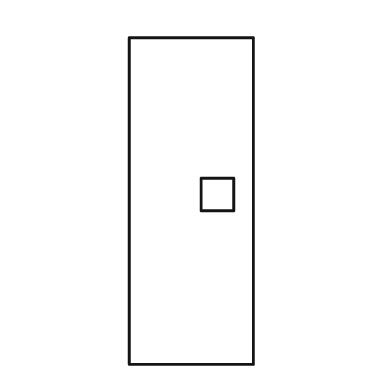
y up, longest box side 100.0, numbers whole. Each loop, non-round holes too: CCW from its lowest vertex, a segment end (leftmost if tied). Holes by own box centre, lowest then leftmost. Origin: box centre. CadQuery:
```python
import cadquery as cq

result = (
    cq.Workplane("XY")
    .moveTo(-19.0, -50.0)
    .lineTo(19.0, -50.0)
    .lineTo(19.0, 50.0)
    .lineTo(-19.0, 50.0)
    .close()
    .moveTo(3.0, -3.0)
    .lineTo(13.0, -3.0)
    .lineTo(13.0, 7.0)
    .lineTo(3.0, 7.0)
    .close()
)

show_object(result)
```